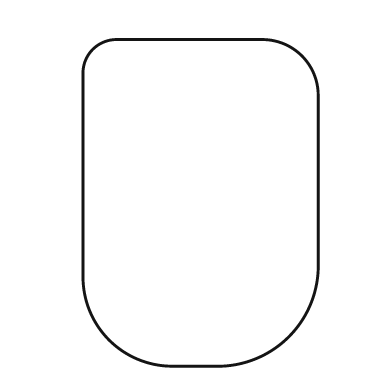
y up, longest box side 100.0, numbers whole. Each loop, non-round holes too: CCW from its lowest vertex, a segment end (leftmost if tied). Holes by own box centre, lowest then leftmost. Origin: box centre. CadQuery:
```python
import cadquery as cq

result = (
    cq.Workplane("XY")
    .moveTo(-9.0, -50.0)
    .lineTo(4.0, -50.0)
    .threePointArc((27.0, -41.0), (36.0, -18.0))
    .lineTo(36.0, 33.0)
    .threePointArc((31.0, 45.0), (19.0, 50.0))
    .lineTo(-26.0, 50.0)
    .threePointArc((-33.0, 47.0), (-36.0, 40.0))
    .lineTo(-36.0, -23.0)
    .threePointArc((-28.0, -42.0), (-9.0, -50.0))
    .close()
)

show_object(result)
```